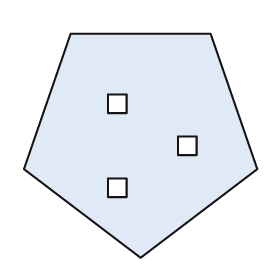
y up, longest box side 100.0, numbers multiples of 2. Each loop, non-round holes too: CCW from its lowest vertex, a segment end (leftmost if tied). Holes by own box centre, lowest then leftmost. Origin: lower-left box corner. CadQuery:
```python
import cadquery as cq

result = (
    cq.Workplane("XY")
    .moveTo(50.0, 0.0)
    .lineTo(100.0, 38.0)
    .lineTo(80.0, 96.0)
    .lineTo(20.0, 96.0)
    .lineTo(0.0, 38.0)
    .close()
    .moveTo(36.0, 26.0)
    .lineTo(44.0, 26.0)
    .lineTo(44.0, 34.0)
    .lineTo(36.0, 34.0)
    .close()
    .moveTo(66.0, 44.0)
    .lineTo(74.0, 44.0)
    .lineTo(74.0, 52.0)
    .lineTo(66.0, 52.0)
    .close()
    .moveTo(36.0, 62.0)
    .lineTo(44.0, 62.0)
    .lineTo(44.0, 70.0)
    .lineTo(36.0, 70.0)
    .close()
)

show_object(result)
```